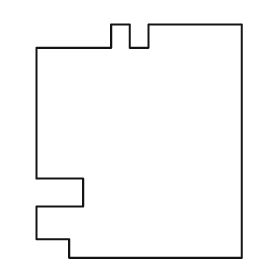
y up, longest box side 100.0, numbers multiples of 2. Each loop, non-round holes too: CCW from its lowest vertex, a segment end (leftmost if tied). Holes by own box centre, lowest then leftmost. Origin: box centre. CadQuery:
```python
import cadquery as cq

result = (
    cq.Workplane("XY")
    .moveTo(-30.0, -50.0)
    .lineTo(44.0, -50.0)
    .lineTo(44.0, 50.0)
    .lineTo(4.0, 50.0)
    .lineTo(4.0, 40.0)
    .lineTo(-4.0, 40.0)
    .lineTo(-4.0, 50.0)
    .lineTo(-12.0, 50.0)
    .lineTo(-12.0, 40.0)
    .lineTo(-44.0, 40.0)
    .lineTo(-44.0, -16.0)
    .lineTo(-24.0, -16.0)
    .lineTo(-24.0, -28.0)
    .lineTo(-44.0, -28.0)
    .lineTo(-44.0, -42.0)
    .lineTo(-30.0, -42.0)
    .close()
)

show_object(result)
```